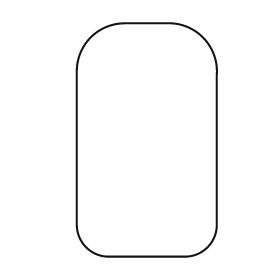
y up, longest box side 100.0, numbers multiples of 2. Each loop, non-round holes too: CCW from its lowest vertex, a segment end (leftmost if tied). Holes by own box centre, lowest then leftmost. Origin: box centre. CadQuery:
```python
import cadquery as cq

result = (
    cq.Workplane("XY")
    .moveTo(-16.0, -50.0)
    .lineTo(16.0, -50.0)
    .threePointArc((26.0, -46.0), (30.0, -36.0))
    .lineTo(30.0, 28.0)
    .threePointArc((24.0, 44.0), (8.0, 50.0))
    .lineTo(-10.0, 50.0)
    .threePointArc((-24.0, 44.0), (-30.0, 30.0))
    .lineTo(-30.0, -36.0)
    .threePointArc((-26.0, -46.0), (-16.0, -50.0))
    .close()
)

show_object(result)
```